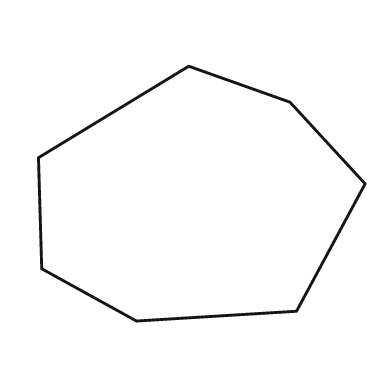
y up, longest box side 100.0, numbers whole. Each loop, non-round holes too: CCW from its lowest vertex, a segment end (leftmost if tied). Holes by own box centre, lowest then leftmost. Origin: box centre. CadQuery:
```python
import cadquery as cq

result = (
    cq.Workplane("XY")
    .moveTo(-20.0, -39.0)
    .lineTo(29.0, -36.0)
    .lineTo(50.0, 3.0)
    .lineTo(27.0, 28.0)
    .lineTo(-4.0, 39.0)
    .lineTo(-50.0, 11.0)
    .lineTo(-49.0, -23.0)
    .close()
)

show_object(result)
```